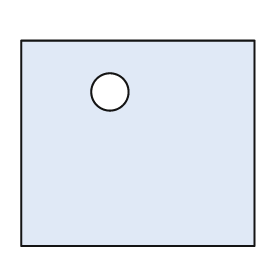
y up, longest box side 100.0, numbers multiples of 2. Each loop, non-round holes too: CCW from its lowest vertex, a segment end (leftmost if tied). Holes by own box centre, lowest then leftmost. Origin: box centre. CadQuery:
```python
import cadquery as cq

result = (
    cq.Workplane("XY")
    .moveTo(-50.0, -44.0)
    .lineTo(50.0, -44.0)
    .lineTo(50.0, 44.0)
    .lineTo(-50.0, 44.0)
    .close()
    .moveTo(-12.0, 22.0)
    .circle(8.0)
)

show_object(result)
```